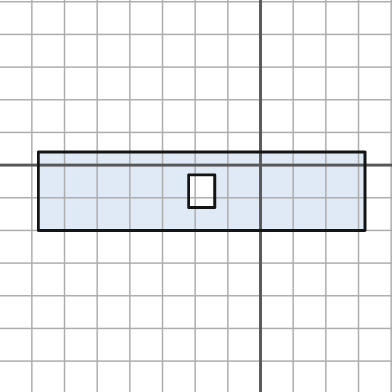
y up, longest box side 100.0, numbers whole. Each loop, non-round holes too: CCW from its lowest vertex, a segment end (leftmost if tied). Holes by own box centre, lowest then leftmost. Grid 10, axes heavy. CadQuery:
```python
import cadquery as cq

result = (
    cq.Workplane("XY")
    .moveTo(-68.0, -20.0)
    .lineTo(32.0, -20.0)
    .lineTo(32.0, 4.0)
    .lineTo(-68.0, 4.0)
    .close()
    .moveTo(-22.0, -13.0)
    .lineTo(-14.0, -13.0)
    .lineTo(-14.0, -3.0)
    .lineTo(-22.0, -3.0)
    .close()
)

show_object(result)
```